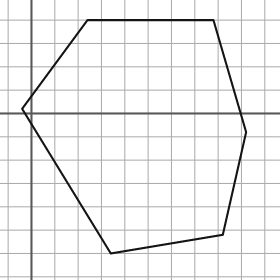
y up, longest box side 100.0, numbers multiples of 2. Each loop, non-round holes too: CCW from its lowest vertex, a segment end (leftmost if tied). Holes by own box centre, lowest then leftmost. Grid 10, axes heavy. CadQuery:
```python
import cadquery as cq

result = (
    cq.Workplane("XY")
    .moveTo(34.0, -60.0)
    .lineTo(82.0, -52.0)
    .lineTo(92.0, -8.0)
    .lineTo(78.0, 40.0)
    .lineTo(24.0, 40.0)
    .lineTo(-4.0, 2.0)
    .close()
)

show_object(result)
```